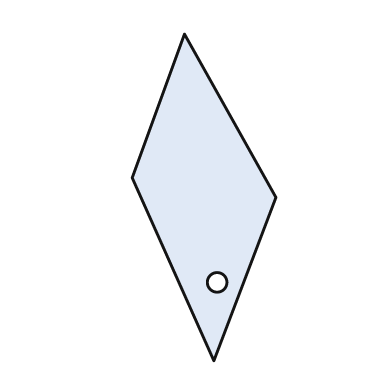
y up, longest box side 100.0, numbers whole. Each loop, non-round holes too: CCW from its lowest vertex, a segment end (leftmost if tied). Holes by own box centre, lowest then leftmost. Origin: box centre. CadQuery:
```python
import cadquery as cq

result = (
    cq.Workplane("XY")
    .moveTo(3.0, -50.0)
    .lineTo(22.0, 0.0)
    .lineTo(-6.0, 50.0)
    .lineTo(-22.0, 6.0)
    .close()
    .moveTo(4.0, -26.0)
    .circle(3.0)
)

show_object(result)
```